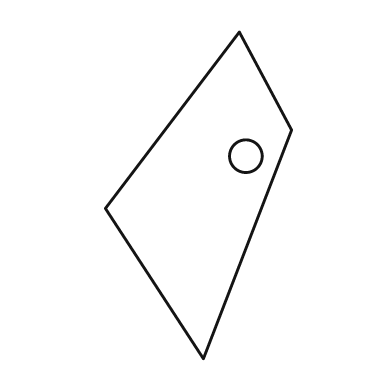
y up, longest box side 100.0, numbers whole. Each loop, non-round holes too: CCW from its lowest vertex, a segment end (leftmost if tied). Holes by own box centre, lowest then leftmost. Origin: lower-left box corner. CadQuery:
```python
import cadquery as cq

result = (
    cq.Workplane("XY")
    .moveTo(30.0, 0.0)
    .lineTo(57.0, 70.0)
    .lineTo(41.0, 100.0)
    .lineTo(0.0, 46.0)
    .close()
    .moveTo(43.0, 62.0)
    .circle(5.0)
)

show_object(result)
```